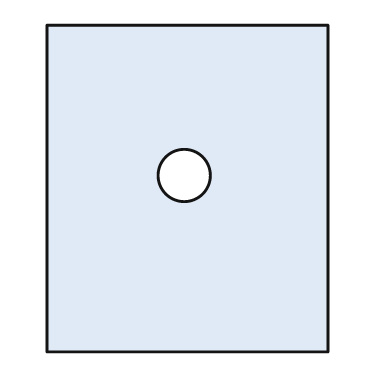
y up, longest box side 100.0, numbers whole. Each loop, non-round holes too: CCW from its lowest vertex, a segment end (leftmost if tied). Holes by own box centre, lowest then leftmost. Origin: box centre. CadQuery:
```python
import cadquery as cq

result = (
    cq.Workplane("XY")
    .moveTo(-43.0, -50.0)
    .lineTo(43.0, -50.0)
    .lineTo(43.0, 50.0)
    .lineTo(-43.0, 50.0)
    .close()
    .moveTo(-1.0, 4.0)
    .circle(8.0)
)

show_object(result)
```